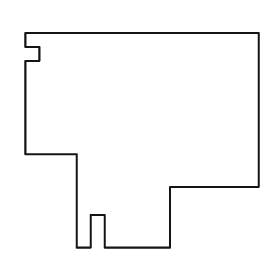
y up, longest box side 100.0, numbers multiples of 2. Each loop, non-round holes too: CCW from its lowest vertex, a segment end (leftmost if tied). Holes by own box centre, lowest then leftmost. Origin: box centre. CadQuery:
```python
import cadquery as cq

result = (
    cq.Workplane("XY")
    .moveTo(-28.0, -46.0)
    .lineTo(-22.0, -46.0)
    .lineTo(-22.0, -32.0)
    .lineTo(-16.0, -32.0)
    .lineTo(-16.0, -46.0)
    .lineTo(12.0, -46.0)
    .lineTo(12.0, -20.0)
    .lineTo(50.0, -20.0)
    .lineTo(50.0, 46.0)
    .lineTo(-50.0, 46.0)
    .lineTo(-50.0, 40.0)
    .lineTo(-44.0, 40.0)
    .lineTo(-44.0, 34.0)
    .lineTo(-50.0, 34.0)
    .lineTo(-50.0, -6.0)
    .lineTo(-28.0, -6.0)
    .close()
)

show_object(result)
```